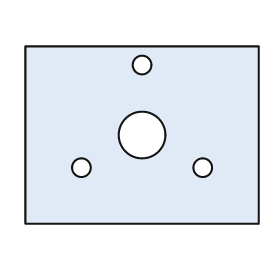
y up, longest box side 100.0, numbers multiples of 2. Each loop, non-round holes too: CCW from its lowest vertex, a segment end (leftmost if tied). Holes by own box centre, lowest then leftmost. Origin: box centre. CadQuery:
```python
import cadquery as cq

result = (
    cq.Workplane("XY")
    .moveTo(-50.0, -38.0)
    .lineTo(50.0, -38.0)
    .lineTo(50.0, 38.0)
    .lineTo(-50.0, 38.0)
    .close()
    .moveTo(-26.0, -14.0)
    .circle(4.0)
    .moveTo(26.0, -14.0)
    .circle(4.0)
    .moveTo(0.0, 0.0)
    .circle(10.0)
    .moveTo(0.0, 30.0)
    .circle(4.0)
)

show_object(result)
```